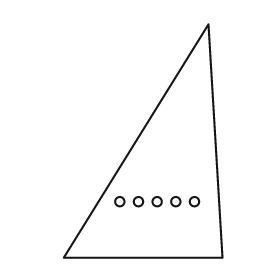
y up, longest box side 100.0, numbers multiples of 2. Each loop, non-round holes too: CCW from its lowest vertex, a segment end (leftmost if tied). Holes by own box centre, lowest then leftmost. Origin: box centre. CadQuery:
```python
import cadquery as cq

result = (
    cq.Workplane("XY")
    .moveTo(-34.0, -50.0)
    .lineTo(34.0, -50.0)
    .lineTo(28.0, 50.0)
    .close()
    .moveTo(-10.0, -26.0)
    .circle(2.0)
    .moveTo(-2.0, -26.0)
    .circle(2.0)
    .moveTo(6.0, -26.0)
    .circle(2.0)
    .moveTo(14.0, -26.0)
    .circle(2.0)
    .moveTo(22.0, -26.0)
    .circle(2.0)
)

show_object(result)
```